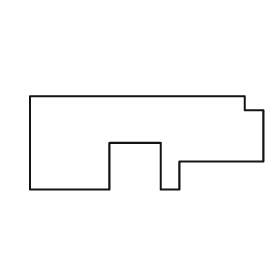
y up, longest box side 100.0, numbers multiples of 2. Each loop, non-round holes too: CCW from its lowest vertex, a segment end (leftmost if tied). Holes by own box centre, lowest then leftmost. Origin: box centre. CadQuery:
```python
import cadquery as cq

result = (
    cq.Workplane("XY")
    .moveTo(-50.0, -20.0)
    .lineTo(-16.0, -20.0)
    .lineTo(-16.0, 0.0)
    .lineTo(6.0, 0.0)
    .lineTo(6.0, -20.0)
    .lineTo(14.0, -20.0)
    .lineTo(14.0, -8.0)
    .lineTo(50.0, -8.0)
    .lineTo(50.0, 14.0)
    .lineTo(42.0, 14.0)
    .lineTo(42.0, 20.0)
    .lineTo(-50.0, 20.0)
    .close()
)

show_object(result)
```